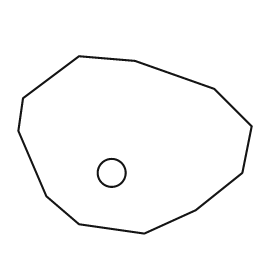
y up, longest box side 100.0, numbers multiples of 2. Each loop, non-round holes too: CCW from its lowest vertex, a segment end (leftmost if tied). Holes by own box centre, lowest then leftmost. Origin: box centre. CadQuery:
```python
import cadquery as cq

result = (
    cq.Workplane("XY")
    .moveTo(4.0, -38.0)
    .lineTo(26.0, -28.0)
    .lineTo(46.0, -12.0)
    .lineTo(50.0, 8.0)
    .lineTo(34.0, 24.0)
    .lineTo(0.0, 36.0)
    .lineTo(-24.0, 38.0)
    .lineTo(-48.0, 20.0)
    .lineTo(-50.0, 6.0)
    .lineTo(-38.0, -22.0)
    .lineTo(-24.0, -34.0)
    .close()
    .moveTo(-10.0, -12.0)
    .circle(6.0)
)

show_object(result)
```